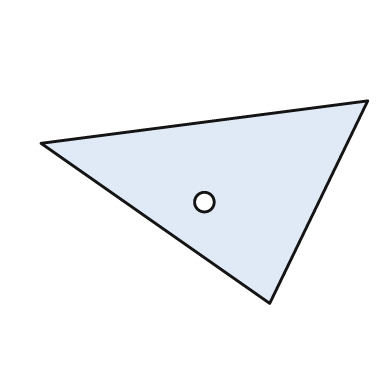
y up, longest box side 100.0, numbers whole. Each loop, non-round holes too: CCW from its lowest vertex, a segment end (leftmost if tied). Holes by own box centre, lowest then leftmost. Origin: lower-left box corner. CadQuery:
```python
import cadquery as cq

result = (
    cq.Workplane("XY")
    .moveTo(70.0, 0.0)
    .lineTo(100.0, 62.0)
    .lineTo(0.0, 49.0)
    .close()
    .moveTo(50.0, 31.0)
    .circle(3.0)
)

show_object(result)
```